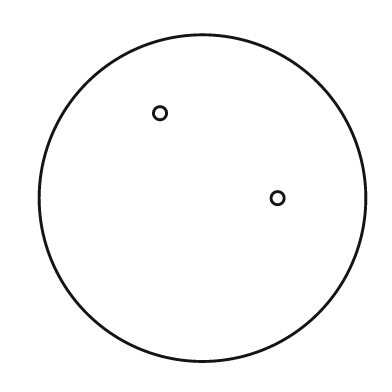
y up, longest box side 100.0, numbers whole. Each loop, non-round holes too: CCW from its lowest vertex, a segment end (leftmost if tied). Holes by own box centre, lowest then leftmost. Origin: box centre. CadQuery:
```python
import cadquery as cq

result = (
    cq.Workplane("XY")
    .moveTo(0.0, 0.0)
    .circle(50.0)
    .moveTo(23.0, 0.0)
    .circle(2.0)
    .moveTo(-13.0, 26.0)
    .circle(2.0)
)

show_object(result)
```